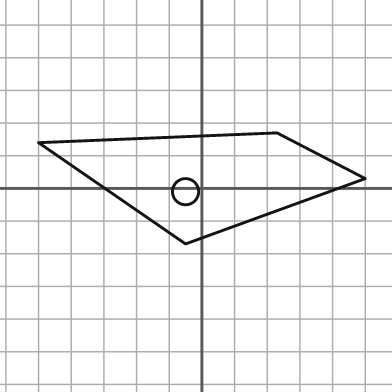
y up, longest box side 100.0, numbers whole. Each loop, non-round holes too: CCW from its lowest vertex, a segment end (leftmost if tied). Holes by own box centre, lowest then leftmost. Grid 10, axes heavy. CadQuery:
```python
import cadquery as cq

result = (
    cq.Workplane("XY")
    .moveTo(-5.0, -17.0)
    .lineTo(50.0, 3.0)
    .lineTo(23.0, 17.0)
    .lineTo(-50.0, 14.0)
    .close()
    .moveTo(-5.0, -1.0)
    .circle(4.0)
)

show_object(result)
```